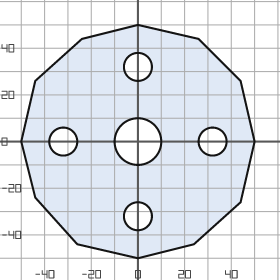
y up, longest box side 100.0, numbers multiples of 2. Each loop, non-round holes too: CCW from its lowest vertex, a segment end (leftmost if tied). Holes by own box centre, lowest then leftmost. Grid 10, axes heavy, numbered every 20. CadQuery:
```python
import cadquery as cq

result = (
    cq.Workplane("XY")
    .moveTo(0.0, -50.0)
    .lineTo(24.0, -44.0)
    .lineTo(44.0, -26.0)
    .lineTo(50.0, 0.0)
    .lineTo(44.0, 26.0)
    .lineTo(26.0, 44.0)
    .lineTo(0.0, 50.0)
    .lineTo(-24.0, 44.0)
    .lineTo(-44.0, 26.0)
    .lineTo(-50.0, 0.0)
    .lineTo(-44.0, -24.0)
    .lineTo(-26.0, -44.0)
    .close()
    .moveTo(0.0, -32.0)
    .circle(6.0)
    .moveTo(-32.0, 0.0)
    .circle(6.0)
    .moveTo(0.0, 0.0)
    .circle(10.0)
    .moveTo(32.0, 0.0)
    .circle(6.0)
    .moveTo(0.0, 32.0)
    .circle(6.0)
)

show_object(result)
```